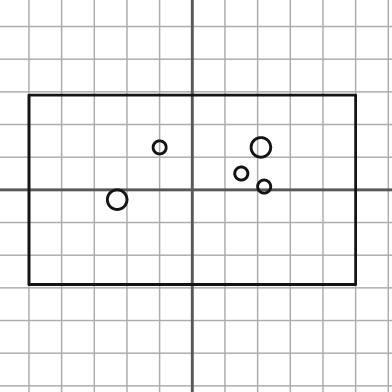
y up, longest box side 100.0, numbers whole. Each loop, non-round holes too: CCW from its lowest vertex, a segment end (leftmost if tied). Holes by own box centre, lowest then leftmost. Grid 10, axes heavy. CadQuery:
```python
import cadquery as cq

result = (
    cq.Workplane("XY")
    .moveTo(-50.0, -29.0)
    .lineTo(50.0, -29.0)
    .lineTo(50.0, 29.0)
    .lineTo(-50.0, 29.0)
    .close()
    .moveTo(-23.0, -3.0)
    .circle(3.0)
    .moveTo(22.0, 1.0)
    .circle(2.0)
    .moveTo(15.0, 5.0)
    .circle(2.0)
    .moveTo(-10.0, 13.0)
    .circle(2.0)
    .moveTo(21.0, 13.0)
    .circle(3.0)
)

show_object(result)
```